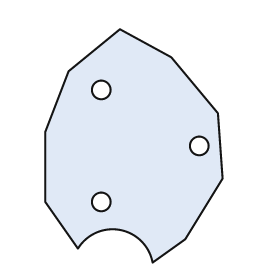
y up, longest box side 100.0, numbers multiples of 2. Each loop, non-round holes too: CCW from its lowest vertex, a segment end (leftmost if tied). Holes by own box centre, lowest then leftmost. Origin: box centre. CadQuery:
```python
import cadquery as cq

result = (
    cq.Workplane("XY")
    .moveTo(8.0, -50.0)
    .lineTo(22.0, -40.0)
    .lineTo(38.0, -14.0)
    .lineTo(36.0, 14.0)
    .lineTo(16.0, 38.0)
    .lineTo(-6.0, 50.0)
    .lineTo(-28.0, 32.0)
    .lineTo(-38.0, 6.0)
    .lineTo(-38.0, -24.0)
    .lineTo(-24.0, -44.0)
    .threePointArc((-6.0, -36.0), (8.0, -50.0))
    .close()
    .moveTo(-14.0, -24.0)
    .circle(4.0)
    .moveTo(28.0, 0.0)
    .circle(4.0)
    .moveTo(-14.0, 24.0)
    .circle(4.0)
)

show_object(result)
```